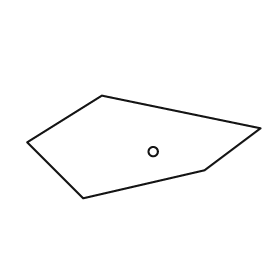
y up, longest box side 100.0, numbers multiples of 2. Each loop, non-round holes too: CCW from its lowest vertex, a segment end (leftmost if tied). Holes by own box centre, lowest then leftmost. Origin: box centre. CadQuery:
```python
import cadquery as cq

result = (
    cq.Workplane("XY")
    .moveTo(-26.0, -22.0)
    .lineTo(26.0, -10.0)
    .lineTo(50.0, 8.0)
    .lineTo(-18.0, 22.0)
    .lineTo(-50.0, 2.0)
    .close()
    .moveTo(4.0, -2.0)
    .circle(2.0)
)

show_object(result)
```